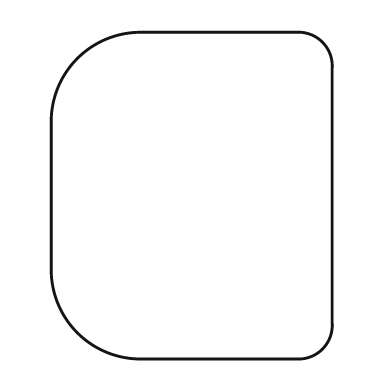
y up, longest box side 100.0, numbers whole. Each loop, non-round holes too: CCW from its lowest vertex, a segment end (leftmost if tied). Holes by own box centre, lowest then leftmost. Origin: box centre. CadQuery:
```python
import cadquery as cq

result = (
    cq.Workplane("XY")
    .moveTo(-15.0, -50.0)
    .lineTo(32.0, -50.0)
    .threePointArc((40.0, -47.0), (43.0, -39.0))
    .lineTo(43.0, 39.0)
    .threePointArc((40.0, 47.0), (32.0, 50.0))
    .lineTo(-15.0, 50.0)
    .threePointArc((-35.0, 42.0), (-43.0, 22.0))
    .lineTo(-43.0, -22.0)
    .threePointArc((-35.0, -42.0), (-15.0, -50.0))
    .close()
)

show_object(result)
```